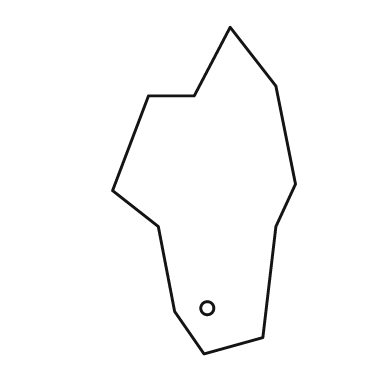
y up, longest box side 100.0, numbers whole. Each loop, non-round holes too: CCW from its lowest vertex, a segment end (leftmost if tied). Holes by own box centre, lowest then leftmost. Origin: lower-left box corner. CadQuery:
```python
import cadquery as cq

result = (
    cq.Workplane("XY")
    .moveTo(28.0, 0.0)
    .lineTo(46.0, 5.0)
    .lineTo(50.0, 39.0)
    .lineTo(56.0, 52.0)
    .lineTo(50.0, 82.0)
    .lineTo(36.0, 100.0)
    .lineTo(25.0, 79.0)
    .lineTo(11.0, 79.0)
    .lineTo(0.0, 50.0)
    .lineTo(14.0, 39.0)
    .lineTo(19.0, 13.0)
    .close()
    .moveTo(29.0, 14.0)
    .circle(2.0)
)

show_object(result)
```